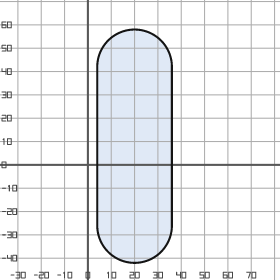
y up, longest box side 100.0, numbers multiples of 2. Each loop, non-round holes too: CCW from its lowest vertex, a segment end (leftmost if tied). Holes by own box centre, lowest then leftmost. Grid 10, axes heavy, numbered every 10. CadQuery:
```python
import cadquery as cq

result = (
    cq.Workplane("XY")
    .moveTo(4.0, -26.0)
    .threePointArc((20.0, -42.0), (36.0, -26.0))
    .lineTo(36.0, 42.0)
    .threePointArc((20.0, 58.0), (4.0, 42.0))
    .close()
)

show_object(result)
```